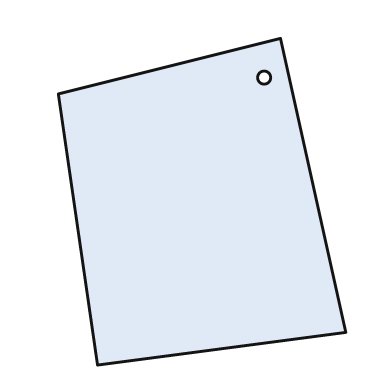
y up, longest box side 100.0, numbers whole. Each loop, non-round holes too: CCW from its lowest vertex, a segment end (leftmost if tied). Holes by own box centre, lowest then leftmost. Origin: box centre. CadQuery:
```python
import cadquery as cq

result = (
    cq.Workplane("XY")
    .moveTo(-32.0, -50.0)
    .lineTo(44.0, -40.0)
    .lineTo(24.0, 50.0)
    .lineTo(-44.0, 33.0)
    .close()
    .moveTo(19.0, 38.0)
    .circle(2.0)
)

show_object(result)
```